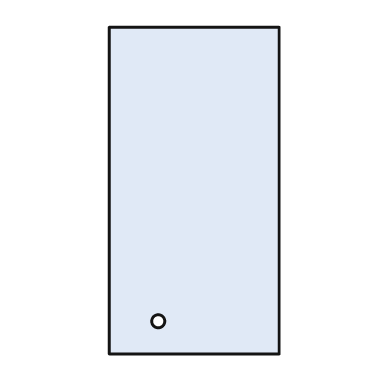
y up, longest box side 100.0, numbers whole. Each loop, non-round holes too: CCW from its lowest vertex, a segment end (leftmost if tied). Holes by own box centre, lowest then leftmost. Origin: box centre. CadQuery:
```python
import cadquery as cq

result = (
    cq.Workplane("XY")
    .moveTo(-26.0, -50.0)
    .lineTo(26.0, -50.0)
    .lineTo(26.0, 50.0)
    .lineTo(-26.0, 50.0)
    .close()
    .moveTo(-11.0, -40.0)
    .circle(2.0)
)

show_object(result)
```